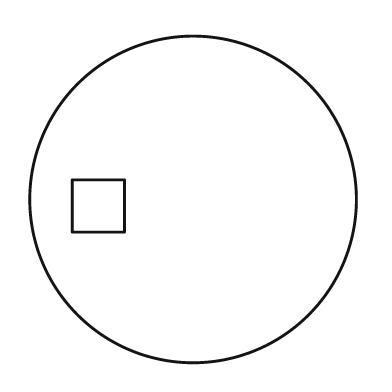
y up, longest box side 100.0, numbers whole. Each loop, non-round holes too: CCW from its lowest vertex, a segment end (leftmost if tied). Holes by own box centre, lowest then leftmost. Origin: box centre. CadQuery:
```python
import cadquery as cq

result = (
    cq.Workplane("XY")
    .moveTo(0.0, 0.0)
    .circle(50.0)
    .moveTo(-37.0, -10.0)
    .lineTo(-21.0, -10.0)
    .lineTo(-21.0, 6.0)
    .lineTo(-37.0, 6.0)
    .close()
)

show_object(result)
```